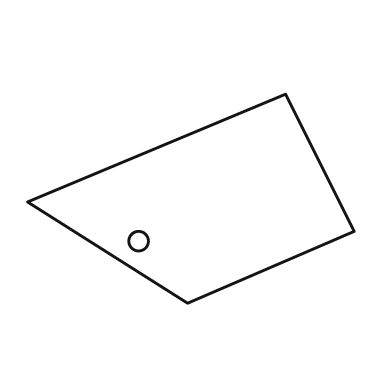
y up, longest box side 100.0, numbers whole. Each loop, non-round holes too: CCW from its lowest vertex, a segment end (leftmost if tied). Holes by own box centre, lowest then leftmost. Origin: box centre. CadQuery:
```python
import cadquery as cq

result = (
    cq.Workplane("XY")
    .moveTo(-1.0, -32.0)
    .lineTo(50.0, -10.0)
    .lineTo(29.0, 32.0)
    .lineTo(-50.0, -1.0)
    .close()
    .moveTo(-16.0, -13.0)
    .circle(3.0)
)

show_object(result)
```